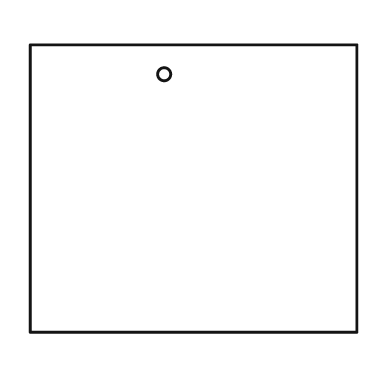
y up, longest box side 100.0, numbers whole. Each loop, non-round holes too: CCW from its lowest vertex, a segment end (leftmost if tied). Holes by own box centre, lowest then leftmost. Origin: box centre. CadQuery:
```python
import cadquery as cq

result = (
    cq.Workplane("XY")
    .moveTo(-50.0, -44.0)
    .lineTo(50.0, -44.0)
    .lineTo(50.0, 44.0)
    .lineTo(-50.0, 44.0)
    .close()
    .moveTo(-9.0, 35.0)
    .circle(2.0)
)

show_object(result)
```